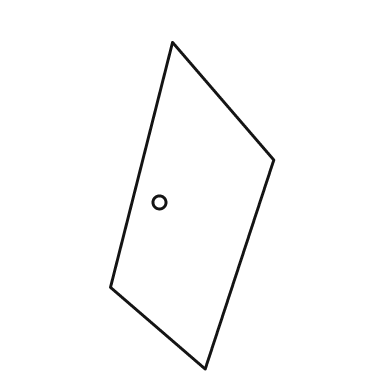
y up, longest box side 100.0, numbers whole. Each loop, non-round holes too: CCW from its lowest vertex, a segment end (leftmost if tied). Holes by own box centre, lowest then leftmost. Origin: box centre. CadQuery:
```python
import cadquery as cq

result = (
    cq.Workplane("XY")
    .moveTo(4.0, -50.0)
    .lineTo(25.0, 14.0)
    .lineTo(-6.0, 50.0)
    .lineTo(-25.0, -25.0)
    .close()
    .moveTo(-10.0, 1.0)
    .circle(2.0)
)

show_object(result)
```